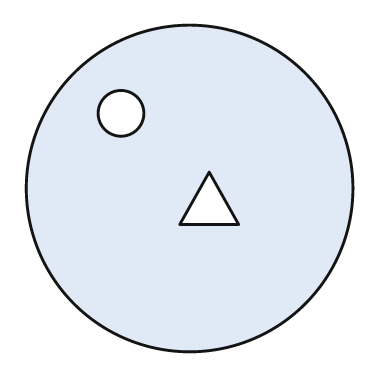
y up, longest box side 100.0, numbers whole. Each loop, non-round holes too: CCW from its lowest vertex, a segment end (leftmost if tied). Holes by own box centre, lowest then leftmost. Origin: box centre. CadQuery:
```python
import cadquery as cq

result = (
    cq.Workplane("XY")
    .moveTo(0.0, 0.0)
    .circle(50.0)
    .moveTo(-3.0, -11.0)
    .lineTo(15.0, -11.0)
    .lineTo(6.0, 5.0)
    .close()
    .moveTo(-21.0, 23.0)
    .circle(7.0)
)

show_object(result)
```